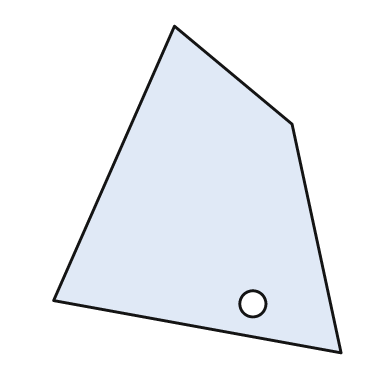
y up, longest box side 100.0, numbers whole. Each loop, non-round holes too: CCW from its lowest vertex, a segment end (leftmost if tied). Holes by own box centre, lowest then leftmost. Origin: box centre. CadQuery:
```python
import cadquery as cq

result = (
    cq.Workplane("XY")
    .moveTo(44.0, -50.0)
    .lineTo(29.0, 20.0)
    .lineTo(-7.0, 50.0)
    .lineTo(-44.0, -34.0)
    .close()
    .moveTo(17.0, -35.0)
    .circle(4.0)
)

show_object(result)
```